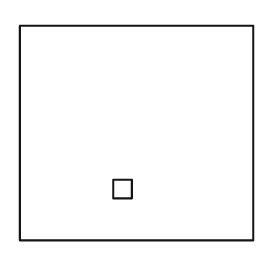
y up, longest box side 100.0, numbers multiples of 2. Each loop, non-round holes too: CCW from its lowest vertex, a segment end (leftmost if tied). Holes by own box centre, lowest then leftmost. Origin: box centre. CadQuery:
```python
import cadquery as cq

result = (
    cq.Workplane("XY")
    .moveTo(-50.0, -46.0)
    .lineTo(50.0, -46.0)
    .lineTo(50.0, 46.0)
    .lineTo(-50.0, 46.0)
    .close()
    .moveTo(-10.0, -28.0)
    .lineTo(-2.0, -28.0)
    .lineTo(-2.0, -20.0)
    .lineTo(-10.0, -20.0)
    .close()
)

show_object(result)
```